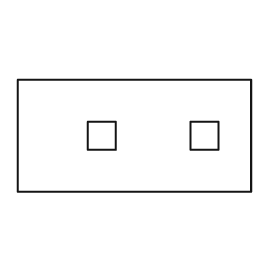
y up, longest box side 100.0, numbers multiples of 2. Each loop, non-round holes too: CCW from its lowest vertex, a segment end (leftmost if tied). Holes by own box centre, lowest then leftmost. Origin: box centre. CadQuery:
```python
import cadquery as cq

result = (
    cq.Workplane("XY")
    .moveTo(-50.0, -24.0)
    .lineTo(50.0, -24.0)
    .lineTo(50.0, 24.0)
    .lineTo(-50.0, 24.0)
    .close()
    .moveTo(-20.0, -6.0)
    .lineTo(-8.0, -6.0)
    .lineTo(-8.0, 6.0)
    .lineTo(-20.0, 6.0)
    .close()
    .moveTo(24.0, -6.0)
    .lineTo(36.0, -6.0)
    .lineTo(36.0, 6.0)
    .lineTo(24.0, 6.0)
    .close()
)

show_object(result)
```